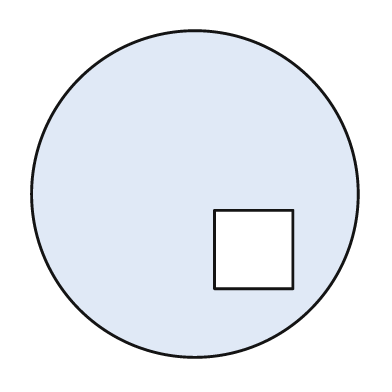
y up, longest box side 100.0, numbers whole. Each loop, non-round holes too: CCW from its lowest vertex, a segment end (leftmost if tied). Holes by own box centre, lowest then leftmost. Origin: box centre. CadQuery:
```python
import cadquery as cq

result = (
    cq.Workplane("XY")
    .moveTo(0.0, 0.0)
    .circle(50.0)
    .moveTo(6.0, -29.0)
    .lineTo(30.0, -29.0)
    .lineTo(30.0, -5.0)
    .lineTo(6.0, -5.0)
    .close()
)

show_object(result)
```